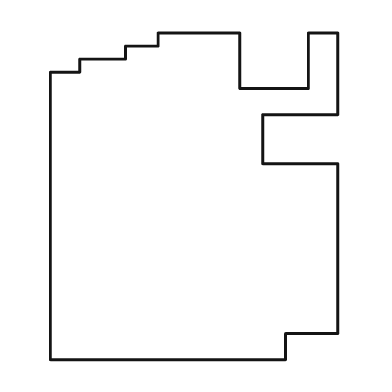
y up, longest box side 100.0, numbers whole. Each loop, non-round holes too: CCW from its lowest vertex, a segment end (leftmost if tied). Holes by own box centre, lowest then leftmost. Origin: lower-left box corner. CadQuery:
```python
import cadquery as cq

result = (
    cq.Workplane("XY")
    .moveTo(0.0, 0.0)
    .lineTo(72.0, 0.0)
    .lineTo(72.0, 8.0)
    .lineTo(88.0, 8.0)
    .lineTo(88.0, 60.0)
    .lineTo(65.0, 60.0)
    .lineTo(65.0, 75.0)
    .lineTo(88.0, 75.0)
    .lineTo(88.0, 100.0)
    .lineTo(79.0, 100.0)
    .lineTo(79.0, 83.0)
    .lineTo(58.0, 83.0)
    .lineTo(58.0, 100.0)
    .lineTo(33.0, 100.0)
    .lineTo(33.0, 96.0)
    .lineTo(23.0, 96.0)
    .lineTo(23.0, 92.0)
    .lineTo(9.0, 92.0)
    .lineTo(9.0, 88.0)
    .lineTo(0.0, 88.0)
    .close()
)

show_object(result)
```